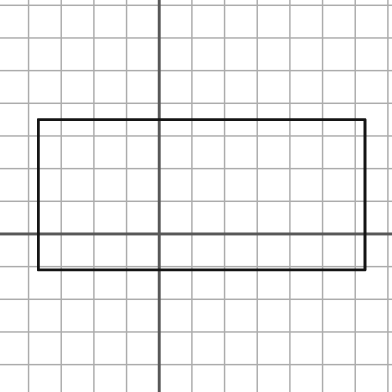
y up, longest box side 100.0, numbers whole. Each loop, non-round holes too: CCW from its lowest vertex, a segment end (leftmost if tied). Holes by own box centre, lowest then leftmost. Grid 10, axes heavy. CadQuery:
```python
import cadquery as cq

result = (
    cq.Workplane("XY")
    .moveTo(-37.0, -11.0)
    .lineTo(63.0, -11.0)
    .lineTo(63.0, 35.0)
    .lineTo(-37.0, 35.0)
    .close()
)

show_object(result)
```